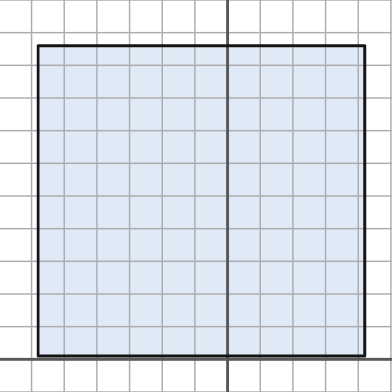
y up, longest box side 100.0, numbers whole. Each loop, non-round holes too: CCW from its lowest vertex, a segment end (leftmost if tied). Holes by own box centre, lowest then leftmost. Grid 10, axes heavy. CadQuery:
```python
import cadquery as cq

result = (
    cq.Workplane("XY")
    .moveTo(-58.0, 1.0)
    .lineTo(42.0, 1.0)
    .lineTo(42.0, 96.0)
    .lineTo(-58.0, 96.0)
    .close()
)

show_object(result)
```